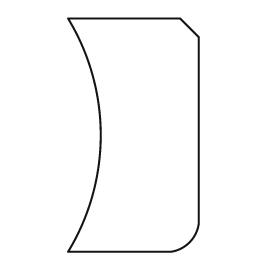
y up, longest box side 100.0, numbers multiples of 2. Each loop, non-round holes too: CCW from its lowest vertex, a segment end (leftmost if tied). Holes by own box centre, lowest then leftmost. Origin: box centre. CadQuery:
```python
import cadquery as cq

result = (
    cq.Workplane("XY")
    .moveTo(-28.0, -50.0)
    .lineTo(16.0, -50.0)
    .threePointArc((24.0, -46.0), (28.0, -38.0))
    .lineTo(28.0, 42.0)
    .lineTo(20.0, 50.0)
    .lineTo(-28.0, 50.0)
    .threePointArc((-14.0, 0.0), (-28.0, -50.0))
    .close()
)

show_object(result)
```